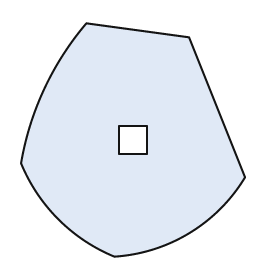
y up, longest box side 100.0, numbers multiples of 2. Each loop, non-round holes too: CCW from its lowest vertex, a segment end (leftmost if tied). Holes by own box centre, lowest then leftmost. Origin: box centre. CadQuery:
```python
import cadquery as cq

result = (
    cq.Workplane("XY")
    .moveTo(-8.0, -50.0)
    .threePointArc((24.0, -40.0), (48.0, -16.0))
    .lineTo(24.0, 44.0)
    .lineTo(-20.0, 50.0)
    .threePointArc((-38.0, 22.0), (-48.0, -10.0))
    .threePointArc((-32.0, -34.0), (-8.0, -50.0))
    .close()
    .moveTo(-6.0, -6.0)
    .lineTo(6.0, -6.0)
    .lineTo(6.0, 6.0)
    .lineTo(-6.0, 6.0)
    .close()
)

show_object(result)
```